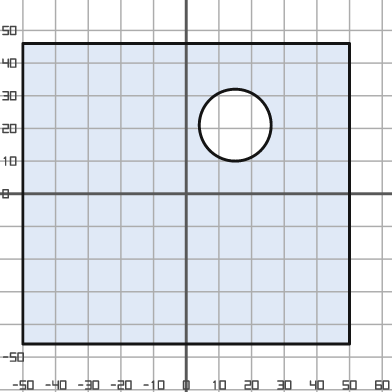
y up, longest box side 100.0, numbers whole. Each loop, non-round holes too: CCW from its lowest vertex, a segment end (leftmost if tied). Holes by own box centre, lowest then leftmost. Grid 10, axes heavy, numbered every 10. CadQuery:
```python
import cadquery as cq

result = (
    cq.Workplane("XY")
    .moveTo(-50.0, -46.0)
    .lineTo(50.0, -46.0)
    .lineTo(50.0, 46.0)
    .lineTo(-50.0, 46.0)
    .close()
    .moveTo(15.0, 21.0)
    .circle(11.0)
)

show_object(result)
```